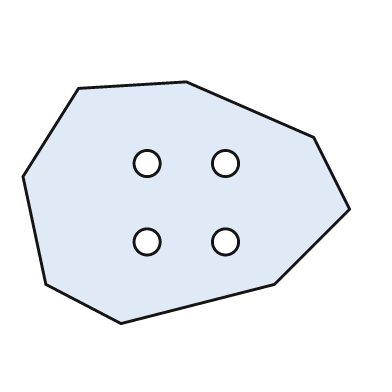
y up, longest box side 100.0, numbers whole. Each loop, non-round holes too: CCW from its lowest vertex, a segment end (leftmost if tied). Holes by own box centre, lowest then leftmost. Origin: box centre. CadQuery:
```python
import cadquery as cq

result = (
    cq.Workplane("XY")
    .moveTo(-20.0, -37.0)
    .lineTo(27.0, -25.0)
    .lineTo(50.0, -2.0)
    .lineTo(39.0, 20.0)
    .lineTo(0.0, 37.0)
    .lineTo(-33.0, 35.0)
    .lineTo(-50.0, 8.0)
    .lineTo(-43.0, -25.0)
    .close()
    .moveTo(-12.0, -12.0)
    .circle(4.0)
    .moveTo(12.0, -12.0)
    .circle(4.0)
    .moveTo(-12.0, 12.0)
    .circle(4.0)
    .moveTo(12.0, 12.0)
    .circle(4.0)
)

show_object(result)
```